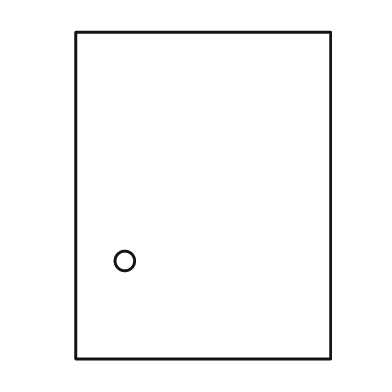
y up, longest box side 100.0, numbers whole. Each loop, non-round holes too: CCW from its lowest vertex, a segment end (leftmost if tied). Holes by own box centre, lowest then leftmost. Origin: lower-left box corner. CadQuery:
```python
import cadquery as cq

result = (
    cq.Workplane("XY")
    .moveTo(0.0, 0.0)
    .lineTo(78.0, 0.0)
    .lineTo(78.0, 100.0)
    .lineTo(0.0, 100.0)
    .close()
    .moveTo(15.0, 30.0)
    .circle(3.0)
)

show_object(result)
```